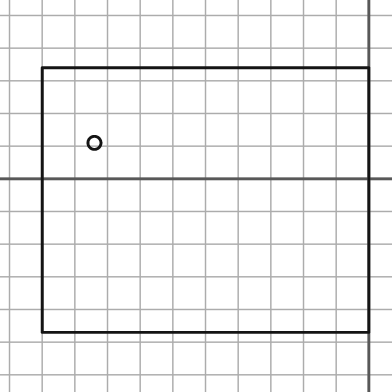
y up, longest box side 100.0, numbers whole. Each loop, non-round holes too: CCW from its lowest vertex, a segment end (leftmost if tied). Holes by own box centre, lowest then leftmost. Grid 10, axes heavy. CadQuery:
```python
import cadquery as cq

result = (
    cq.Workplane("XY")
    .moveTo(-100.0, -47.0)
    .lineTo(0.0, -47.0)
    .lineTo(0.0, 34.0)
    .lineTo(-100.0, 34.0)
    .close()
    .moveTo(-84.0, 11.0)
    .circle(2.0)
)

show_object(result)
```